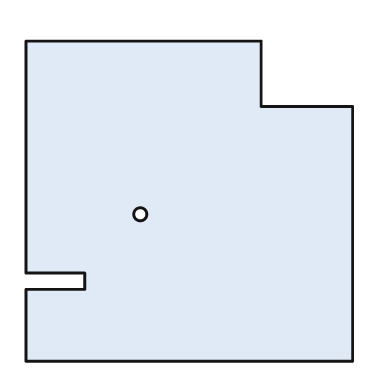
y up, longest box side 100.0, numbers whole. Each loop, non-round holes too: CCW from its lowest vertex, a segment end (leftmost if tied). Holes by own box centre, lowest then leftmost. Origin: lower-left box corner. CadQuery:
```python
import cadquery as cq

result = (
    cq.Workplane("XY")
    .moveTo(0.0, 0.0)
    .lineTo(100.0, 0.0)
    .lineTo(100.0, 78.0)
    .lineTo(72.0, 78.0)
    .lineTo(72.0, 98.0)
    .lineTo(0.0, 98.0)
    .lineTo(0.0, 27.0)
    .lineTo(18.0, 27.0)
    .lineTo(18.0, 22.0)
    .lineTo(0.0, 22.0)
    .close()
    .moveTo(35.0, 45.0)
    .circle(2.0)
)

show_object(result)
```